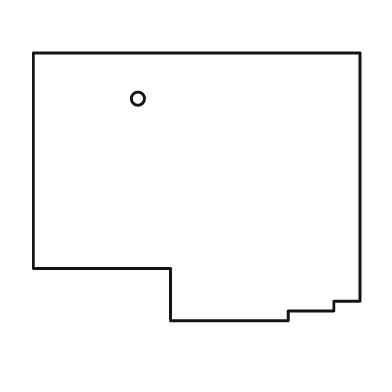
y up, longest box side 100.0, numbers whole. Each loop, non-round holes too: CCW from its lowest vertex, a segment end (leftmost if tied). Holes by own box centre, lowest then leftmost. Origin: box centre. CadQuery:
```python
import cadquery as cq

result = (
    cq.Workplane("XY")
    .moveTo(-8.0, -41.0)
    .lineTo(28.0, -41.0)
    .lineTo(28.0, -38.0)
    .lineTo(42.0, -38.0)
    .lineTo(42.0, -35.0)
    .lineTo(50.0, -35.0)
    .lineTo(50.0, 41.0)
    .lineTo(-50.0, 41.0)
    .lineTo(-50.0, -25.0)
    .lineTo(-8.0, -25.0)
    .close()
    .moveTo(-18.0, 27.0)
    .circle(2.0)
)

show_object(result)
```